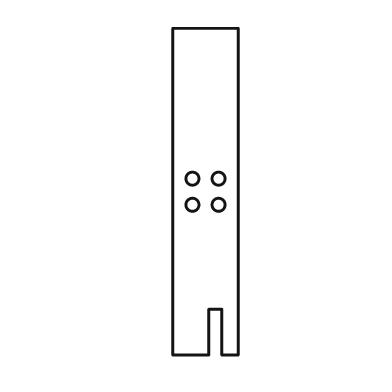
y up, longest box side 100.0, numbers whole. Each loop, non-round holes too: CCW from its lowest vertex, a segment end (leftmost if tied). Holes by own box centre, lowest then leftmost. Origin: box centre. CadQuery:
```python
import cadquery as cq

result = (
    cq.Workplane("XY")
    .moveTo(-10.0, -50.0)
    .lineTo(1.0, -50.0)
    .lineTo(1.0, -36.0)
    .lineTo(5.0, -36.0)
    .lineTo(5.0, -50.0)
    .lineTo(10.0, -50.0)
    .lineTo(10.0, 50.0)
    .lineTo(-10.0, 50.0)
    .close()
    .moveTo(-4.0, -4.0)
    .circle(2.0)
    .moveTo(4.0, -4.0)
    .circle(2.0)
    .moveTo(-4.0, 4.0)
    .circle(2.0)
    .moveTo(4.0, 4.0)
    .circle(2.0)
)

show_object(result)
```